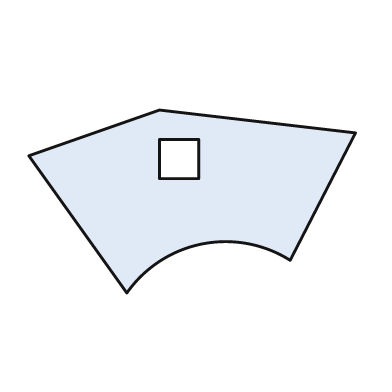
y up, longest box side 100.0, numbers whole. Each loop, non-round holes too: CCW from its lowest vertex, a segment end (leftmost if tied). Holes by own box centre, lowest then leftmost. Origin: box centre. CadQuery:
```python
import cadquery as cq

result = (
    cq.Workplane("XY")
    .moveTo(-20.0, -28.0)
    .threePointArc((3.0, -13.0), (30.0, -18.0))
    .lineTo(50.0, 21.0)
    .lineTo(-10.0, 28.0)
    .lineTo(-50.0, 14.0)
    .close()
    .moveTo(-10.0, 7.0)
    .lineTo(2.0, 7.0)
    .lineTo(2.0, 19.0)
    .lineTo(-10.0, 19.0)
    .close()
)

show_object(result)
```